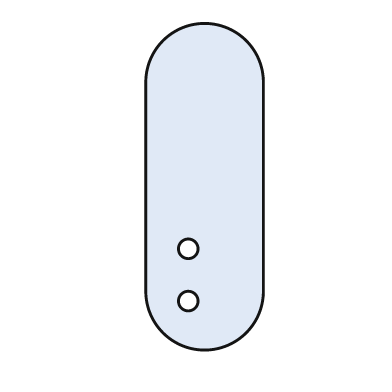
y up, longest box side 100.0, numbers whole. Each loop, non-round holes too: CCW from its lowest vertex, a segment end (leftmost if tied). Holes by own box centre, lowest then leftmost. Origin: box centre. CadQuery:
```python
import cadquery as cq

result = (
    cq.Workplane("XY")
    .moveTo(-18.0, -32.0)
    .threePointArc((0.0, -50.0), (18.0, -32.0))
    .lineTo(18.0, 32.0)
    .threePointArc((0.0, 50.0), (-18.0, 32.0))
    .close()
    .moveTo(-5.0, -35.0)
    .circle(3.0)
    .moveTo(-5.0, -19.0)
    .circle(3.0)
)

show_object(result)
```